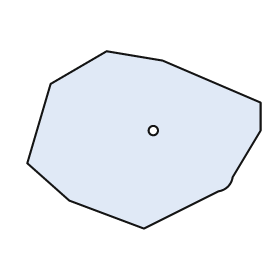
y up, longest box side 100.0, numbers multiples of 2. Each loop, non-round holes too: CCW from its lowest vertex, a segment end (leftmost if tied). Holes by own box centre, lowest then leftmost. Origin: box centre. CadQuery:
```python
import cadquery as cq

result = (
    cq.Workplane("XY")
    .moveTo(0.0, -38.0)
    .lineTo(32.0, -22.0)
    .threePointArc((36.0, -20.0), (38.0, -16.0))
    .lineTo(50.0, 4.0)
    .lineTo(50.0, 16.0)
    .lineTo(8.0, 34.0)
    .lineTo(-16.0, 38.0)
    .lineTo(-40.0, 24.0)
    .lineTo(-50.0, -10.0)
    .lineTo(-32.0, -26.0)
    .close()
    .moveTo(4.0, 4.0)
    .circle(2.0)
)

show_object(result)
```